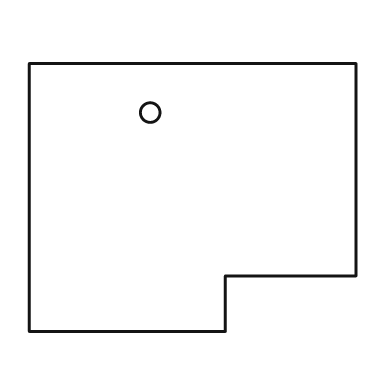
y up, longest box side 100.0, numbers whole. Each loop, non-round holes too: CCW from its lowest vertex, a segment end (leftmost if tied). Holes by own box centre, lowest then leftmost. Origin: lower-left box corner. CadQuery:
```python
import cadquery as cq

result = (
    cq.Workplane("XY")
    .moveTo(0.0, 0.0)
    .lineTo(60.0, 0.0)
    .lineTo(60.0, 17.0)
    .lineTo(100.0, 17.0)
    .lineTo(100.0, 82.0)
    .lineTo(0.0, 82.0)
    .close()
    .moveTo(37.0, 67.0)
    .circle(3.0)
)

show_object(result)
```